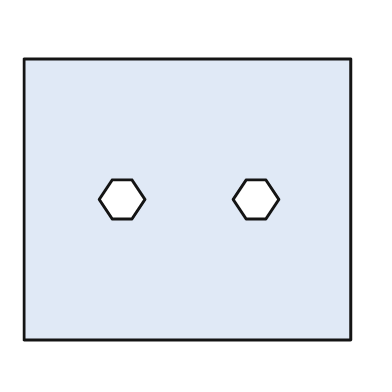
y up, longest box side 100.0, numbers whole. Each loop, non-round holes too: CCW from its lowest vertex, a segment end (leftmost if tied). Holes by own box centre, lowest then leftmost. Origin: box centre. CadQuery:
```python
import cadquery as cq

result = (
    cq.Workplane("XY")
    .moveTo(-50.0, -43.0)
    .lineTo(50.0, -43.0)
    .lineTo(50.0, 43.0)
    .lineTo(-50.0, 43.0)
    .close()
    .moveTo(-23.0, -6.0)
    .lineTo(-17.0, -6.0)
    .lineTo(-13.0, 0.0)
    .lineTo(-17.0, 6.0)
    .lineTo(-23.0, 6.0)
    .lineTo(-27.0, 0.0)
    .close()
    .moveTo(18.0, -6.0)
    .lineTo(24.0, -6.0)
    .lineTo(28.0, 0.0)
    .lineTo(24.0, 6.0)
    .lineTo(18.0, 6.0)
    .lineTo(14.0, 0.0)
    .close()
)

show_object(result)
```